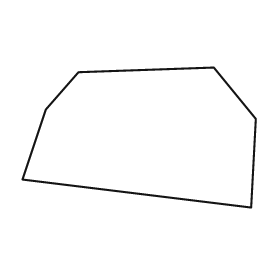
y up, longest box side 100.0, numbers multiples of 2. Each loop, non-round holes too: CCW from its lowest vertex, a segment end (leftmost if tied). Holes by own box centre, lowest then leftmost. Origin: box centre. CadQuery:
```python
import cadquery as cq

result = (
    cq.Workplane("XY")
    .moveTo(48.0, -30.0)
    .lineTo(50.0, 8.0)
    .lineTo(32.0, 30.0)
    .lineTo(-26.0, 28.0)
    .lineTo(-40.0, 12.0)
    .lineTo(-50.0, -18.0)
    .close()
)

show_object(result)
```